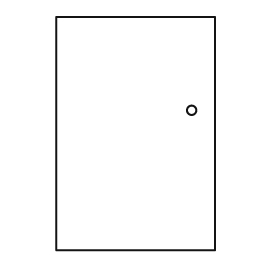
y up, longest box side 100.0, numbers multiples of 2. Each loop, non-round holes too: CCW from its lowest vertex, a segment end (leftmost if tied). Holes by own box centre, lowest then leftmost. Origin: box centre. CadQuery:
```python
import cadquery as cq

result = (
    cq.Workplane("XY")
    .moveTo(-34.0, -50.0)
    .lineTo(34.0, -50.0)
    .lineTo(34.0, 50.0)
    .lineTo(-34.0, 50.0)
    .close()
    .moveTo(24.0, 10.0)
    .circle(2.0)
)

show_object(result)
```